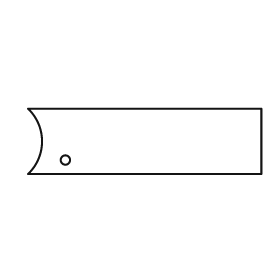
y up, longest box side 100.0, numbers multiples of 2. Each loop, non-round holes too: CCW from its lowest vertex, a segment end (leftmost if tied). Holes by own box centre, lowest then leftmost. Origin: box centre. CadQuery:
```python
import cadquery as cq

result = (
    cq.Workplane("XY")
    .moveTo(-50.0, -14.0)
    .lineTo(50.0, -14.0)
    .lineTo(50.0, 14.0)
    .lineTo(-50.0, 14.0)
    .threePointArc((-44.0, 0.0), (-50.0, -14.0))
    .close()
    .moveTo(-34.0, -8.0)
    .circle(2.0)
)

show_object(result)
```